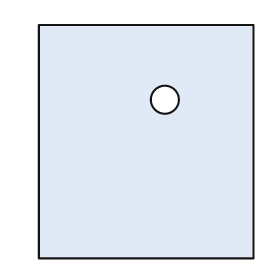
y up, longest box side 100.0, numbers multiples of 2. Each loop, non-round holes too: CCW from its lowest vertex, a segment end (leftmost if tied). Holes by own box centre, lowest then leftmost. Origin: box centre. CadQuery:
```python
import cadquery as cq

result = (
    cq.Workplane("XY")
    .moveTo(-46.0, -50.0)
    .lineTo(46.0, -50.0)
    .lineTo(46.0, 50.0)
    .lineTo(-46.0, 50.0)
    .close()
    .moveTo(8.0, 18.0)
    .circle(6.0)
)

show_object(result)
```